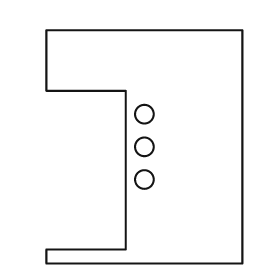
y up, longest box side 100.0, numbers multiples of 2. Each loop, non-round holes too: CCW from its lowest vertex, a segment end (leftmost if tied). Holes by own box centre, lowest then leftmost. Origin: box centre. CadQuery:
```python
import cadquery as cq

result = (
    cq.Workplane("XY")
    .moveTo(-42.0, -50.0)
    .lineTo(42.0, -50.0)
    .lineTo(42.0, 50.0)
    .lineTo(-42.0, 50.0)
    .lineTo(-42.0, 24.0)
    .lineTo(-8.0, 24.0)
    .lineTo(-8.0, -44.0)
    .lineTo(-42.0, -44.0)
    .close()
    .moveTo(0.0, -14.0)
    .circle(4.0)
    .moveTo(0.0, 0.0)
    .circle(4.0)
    .moveTo(0.0, 14.0)
    .circle(4.0)
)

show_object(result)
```